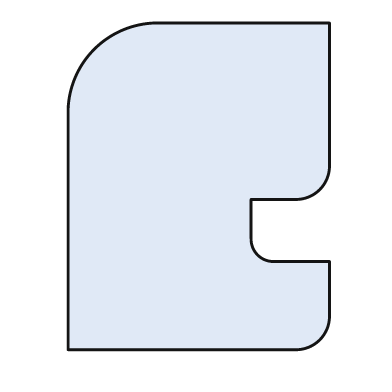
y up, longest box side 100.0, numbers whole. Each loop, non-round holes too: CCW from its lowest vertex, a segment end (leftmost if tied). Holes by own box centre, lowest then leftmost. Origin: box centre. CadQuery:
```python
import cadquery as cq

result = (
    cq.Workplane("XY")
    .moveTo(-40.0, -50.0)
    .lineTo(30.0, -50.0)
    .threePointArc((37.0, -47.0), (40.0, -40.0))
    .lineTo(40.0, -23.0)
    .lineTo(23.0, -23.0)
    .threePointArc((18.0, -21.0), (16.0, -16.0))
    .lineTo(16.0, -4.0)
    .lineTo(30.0, -4.0)
    .threePointArc((37.0, -1.0), (40.0, 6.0))
    .lineTo(40.0, 50.0)
    .lineTo(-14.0, 50.0)
    .threePointArc((-32.0, 42.0), (-40.0, 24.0))
    .close()
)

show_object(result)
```